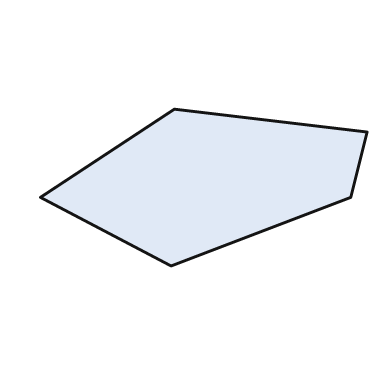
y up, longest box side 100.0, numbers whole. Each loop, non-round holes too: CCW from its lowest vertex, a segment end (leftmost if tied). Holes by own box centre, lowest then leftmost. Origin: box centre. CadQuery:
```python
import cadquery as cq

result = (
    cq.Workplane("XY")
    .moveTo(-10.0, -24.0)
    .lineTo(45.0, -3.0)
    .lineTo(50.0, 17.0)
    .lineTo(-9.0, 24.0)
    .lineTo(-50.0, -3.0)
    .close()
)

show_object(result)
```